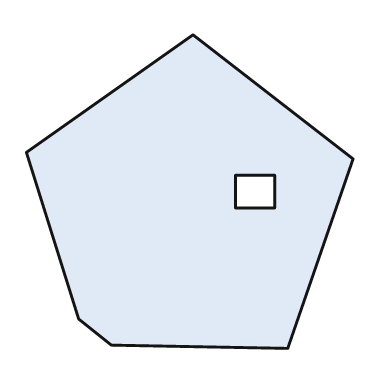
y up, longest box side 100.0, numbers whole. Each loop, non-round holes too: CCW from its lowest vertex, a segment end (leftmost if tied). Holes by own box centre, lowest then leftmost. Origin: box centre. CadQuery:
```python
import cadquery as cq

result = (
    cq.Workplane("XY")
    .moveTo(30.0, -48.0)
    .lineTo(50.0, 10.0)
    .lineTo(1.0, 48.0)
    .lineTo(-50.0, 12.0)
    .lineTo(-34.0, -39.0)
    .lineTo(-24.0, -47.0)
    .close()
    .moveTo(14.0, -5.0)
    .lineTo(26.0, -5.0)
    .lineTo(26.0, 5.0)
    .lineTo(14.0, 5.0)
    .close()
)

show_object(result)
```